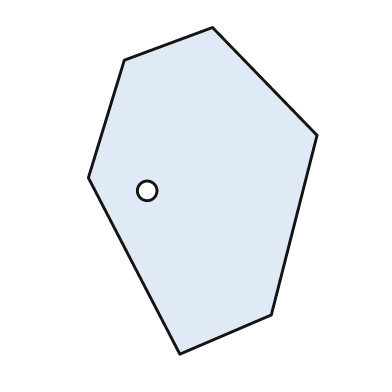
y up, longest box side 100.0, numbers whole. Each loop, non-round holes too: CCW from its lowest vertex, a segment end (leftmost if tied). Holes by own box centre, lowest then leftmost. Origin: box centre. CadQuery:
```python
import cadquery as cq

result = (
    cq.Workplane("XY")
    .moveTo(-7.0, -50.0)
    .lineTo(21.0, -38.0)
    .lineTo(35.0, 17.0)
    .lineTo(3.0, 50.0)
    .lineTo(-24.0, 40.0)
    .lineTo(-35.0, 4.0)
    .close()
    .moveTo(-17.0, 0.0)
    .circle(3.0)
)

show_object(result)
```